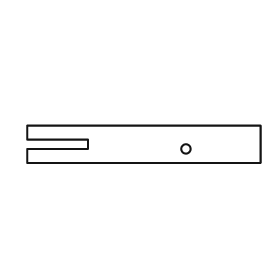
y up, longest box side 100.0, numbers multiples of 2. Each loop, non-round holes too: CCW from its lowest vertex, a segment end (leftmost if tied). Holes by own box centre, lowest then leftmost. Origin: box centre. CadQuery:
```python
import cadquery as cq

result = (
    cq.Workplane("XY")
    .moveTo(-50.0, -8.0)
    .lineTo(50.0, -8.0)
    .lineTo(50.0, 8.0)
    .lineTo(-50.0, 8.0)
    .lineTo(-50.0, 2.0)
    .lineTo(-24.0, 2.0)
    .lineTo(-24.0, -2.0)
    .lineTo(-50.0, -2.0)
    .close()
    .moveTo(18.0, -2.0)
    .circle(2.0)
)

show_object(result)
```